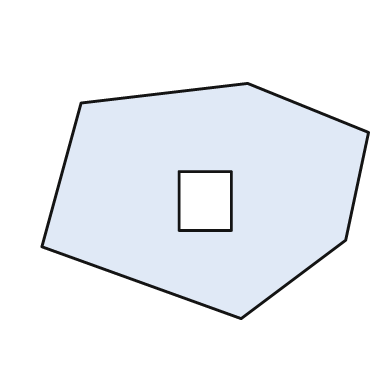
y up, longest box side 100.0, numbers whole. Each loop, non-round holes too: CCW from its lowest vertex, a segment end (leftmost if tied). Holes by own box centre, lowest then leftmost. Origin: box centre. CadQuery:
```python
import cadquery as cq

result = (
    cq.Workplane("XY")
    .moveTo(11.0, -36.0)
    .lineTo(43.0, -12.0)
    .lineTo(50.0, 21.0)
    .lineTo(13.0, 36.0)
    .lineTo(-38.0, 30.0)
    .lineTo(-50.0, -14.0)
    .close()
    .moveTo(-8.0, -9.0)
    .lineTo(8.0, -9.0)
    .lineTo(8.0, 9.0)
    .lineTo(-8.0, 9.0)
    .close()
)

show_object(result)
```